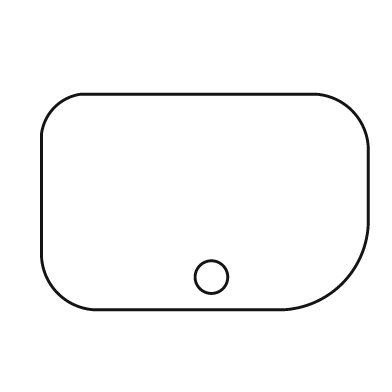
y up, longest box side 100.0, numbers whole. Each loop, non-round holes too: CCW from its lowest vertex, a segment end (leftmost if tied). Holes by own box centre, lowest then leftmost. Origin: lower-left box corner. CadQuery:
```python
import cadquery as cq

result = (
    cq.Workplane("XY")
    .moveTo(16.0, 0.0)
    .lineTo(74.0, 0.0)
    .threePointArc((92.0, 8.0), (100.0, 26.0))
    .lineTo(100.0, 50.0)
    .threePointArc((95.0, 61.0), (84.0, 66.0))
    .lineTo(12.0, 66.0)
    .threePointArc((4.0, 62.0), (0.0, 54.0))
    .lineTo(0.0, 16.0)
    .threePointArc((5.0, 5.0), (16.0, 0.0))
    .close()
    .moveTo(52.0, 10.0)
    .circle(5.0)
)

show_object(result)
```